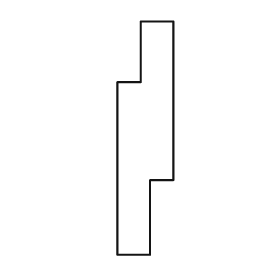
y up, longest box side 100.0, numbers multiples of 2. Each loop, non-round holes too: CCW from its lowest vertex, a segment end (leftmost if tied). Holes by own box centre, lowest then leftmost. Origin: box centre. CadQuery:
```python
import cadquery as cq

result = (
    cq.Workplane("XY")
    .moveTo(-12.0, -50.0)
    .lineTo(2.0, -50.0)
    .lineTo(2.0, -18.0)
    .lineTo(12.0, -18.0)
    .lineTo(12.0, 50.0)
    .lineTo(-2.0, 50.0)
    .lineTo(-2.0, 24.0)
    .lineTo(-12.0, 24.0)
    .close()
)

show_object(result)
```